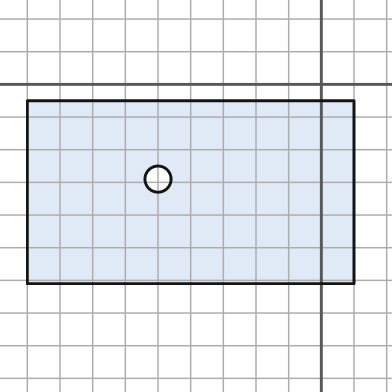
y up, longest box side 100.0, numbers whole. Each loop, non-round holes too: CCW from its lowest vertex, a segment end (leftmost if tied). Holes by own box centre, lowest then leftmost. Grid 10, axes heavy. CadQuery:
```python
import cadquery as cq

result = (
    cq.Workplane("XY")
    .moveTo(-90.0, -61.0)
    .lineTo(10.0, -61.0)
    .lineTo(10.0, -5.0)
    .lineTo(-90.0, -5.0)
    .close()
    .moveTo(-50.0, -29.0)
    .circle(4.0)
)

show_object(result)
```